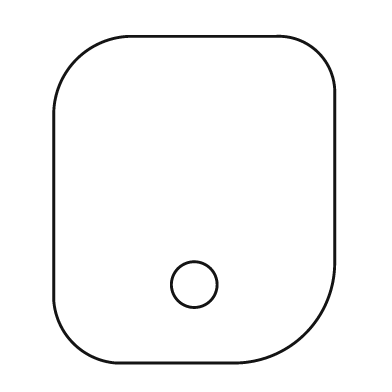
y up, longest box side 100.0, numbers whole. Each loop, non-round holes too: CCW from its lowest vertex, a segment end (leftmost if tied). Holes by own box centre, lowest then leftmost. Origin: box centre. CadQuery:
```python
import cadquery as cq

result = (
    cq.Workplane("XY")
    .moveTo(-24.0, -50.0)
    .lineTo(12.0, -50.0)
    .threePointArc((34.0, -41.0), (43.0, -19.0))
    .lineTo(43.0, 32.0)
    .threePointArc((38.0, 45.0), (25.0, 50.0))
    .lineTo(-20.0, 50.0)
    .threePointArc((-36.0, 43.0), (-43.0, 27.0))
    .lineTo(-43.0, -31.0)
    .threePointArc((-37.0, -44.0), (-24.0, -50.0))
    .close()
    .moveTo(0.0, -26.0)
    .circle(7.0)
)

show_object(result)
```